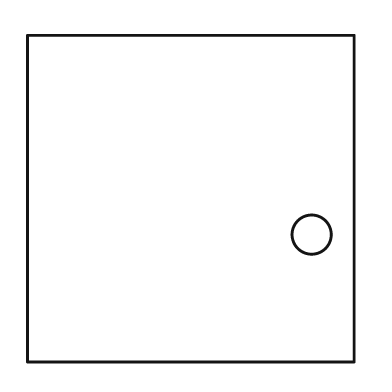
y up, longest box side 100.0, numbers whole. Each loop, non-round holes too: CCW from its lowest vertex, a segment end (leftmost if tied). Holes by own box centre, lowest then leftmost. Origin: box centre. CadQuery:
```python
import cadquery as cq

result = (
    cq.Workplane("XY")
    .moveTo(-50.0, -50.0)
    .lineTo(50.0, -50.0)
    .lineTo(50.0, 50.0)
    .lineTo(-50.0, 50.0)
    .close()
    .moveTo(37.0, -11.0)
    .circle(6.0)
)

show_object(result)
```